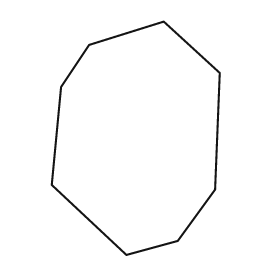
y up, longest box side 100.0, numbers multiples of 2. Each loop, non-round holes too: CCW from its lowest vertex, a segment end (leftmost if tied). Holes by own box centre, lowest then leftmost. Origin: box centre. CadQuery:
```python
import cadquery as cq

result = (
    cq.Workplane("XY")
    .moveTo(-4.0, -50.0)
    .lineTo(18.0, -44.0)
    .lineTo(34.0, -22.0)
    .lineTo(36.0, 28.0)
    .lineTo(12.0, 50.0)
    .lineTo(-20.0, 40.0)
    .lineTo(-32.0, 22.0)
    .lineTo(-36.0, -20.0)
    .close()
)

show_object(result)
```